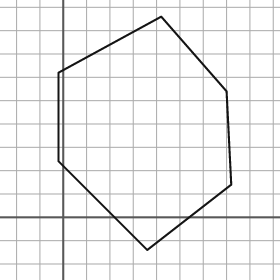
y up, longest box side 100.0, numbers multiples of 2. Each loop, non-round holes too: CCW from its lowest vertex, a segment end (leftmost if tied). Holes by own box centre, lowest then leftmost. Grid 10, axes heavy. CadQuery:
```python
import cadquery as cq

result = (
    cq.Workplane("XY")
    .moveTo(36.0, -14.0)
    .lineTo(72.0, 14.0)
    .lineTo(70.0, 54.0)
    .lineTo(42.0, 86.0)
    .lineTo(-2.0, 62.0)
    .lineTo(-2.0, 24.0)
    .close()
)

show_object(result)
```